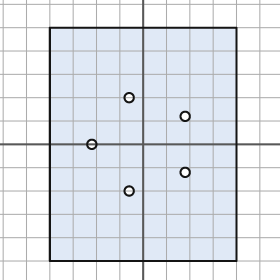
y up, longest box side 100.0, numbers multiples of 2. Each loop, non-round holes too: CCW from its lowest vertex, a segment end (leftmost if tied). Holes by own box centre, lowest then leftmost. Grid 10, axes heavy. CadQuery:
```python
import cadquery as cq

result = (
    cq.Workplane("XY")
    .moveTo(-40.0, -50.0)
    .lineTo(40.0, -50.0)
    .lineTo(40.0, 50.0)
    .lineTo(-40.0, 50.0)
    .close()
    .moveTo(-6.0, -20.0)
    .circle(2.0)
    .moveTo(18.0, -12.0)
    .circle(2.0)
    .moveTo(-22.0, 0.0)
    .circle(2.0)
    .moveTo(18.0, 12.0)
    .circle(2.0)
    .moveTo(-6.0, 20.0)
    .circle(2.0)
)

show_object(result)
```